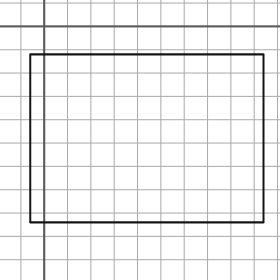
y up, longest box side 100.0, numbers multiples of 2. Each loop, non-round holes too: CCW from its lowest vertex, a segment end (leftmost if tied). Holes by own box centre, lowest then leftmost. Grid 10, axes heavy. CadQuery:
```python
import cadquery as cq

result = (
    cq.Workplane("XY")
    .moveTo(-6.0, -84.0)
    .lineTo(94.0, -84.0)
    .lineTo(94.0, -12.0)
    .lineTo(-6.0, -12.0)
    .close()
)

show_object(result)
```